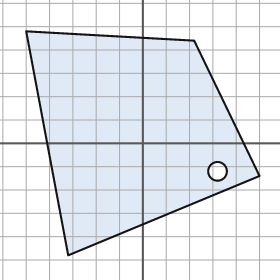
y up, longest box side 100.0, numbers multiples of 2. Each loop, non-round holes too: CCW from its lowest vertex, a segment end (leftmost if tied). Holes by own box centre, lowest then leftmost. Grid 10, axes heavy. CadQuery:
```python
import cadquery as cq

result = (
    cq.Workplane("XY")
    .moveTo(-32.0, -48.0)
    .lineTo(50.0, -14.0)
    .lineTo(22.0, 44.0)
    .lineTo(-50.0, 48.0)
    .close()
    .moveTo(32.0, -12.0)
    .circle(4.0)
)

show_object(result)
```